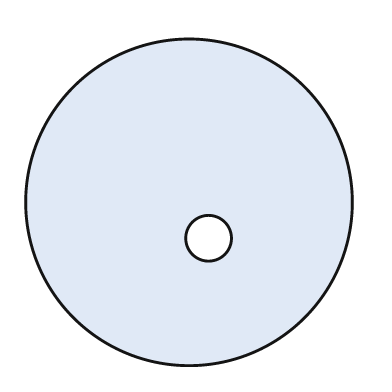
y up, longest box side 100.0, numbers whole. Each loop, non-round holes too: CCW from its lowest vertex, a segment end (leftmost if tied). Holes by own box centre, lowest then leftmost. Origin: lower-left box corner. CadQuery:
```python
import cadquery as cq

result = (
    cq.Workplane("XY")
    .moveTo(50.0, 50.0)
    .circle(50.0)
    .moveTo(56.0, 39.0)
    .circle(7.0)
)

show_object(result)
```